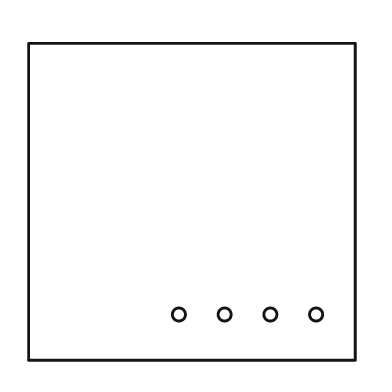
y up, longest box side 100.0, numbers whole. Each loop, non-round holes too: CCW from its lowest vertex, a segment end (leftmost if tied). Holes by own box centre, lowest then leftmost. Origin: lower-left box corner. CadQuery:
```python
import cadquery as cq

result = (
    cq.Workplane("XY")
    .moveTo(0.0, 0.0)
    .lineTo(100.0, 0.0)
    .lineTo(100.0, 97.0)
    .lineTo(0.0, 97.0)
    .close()
    .moveTo(46.0, 14.0)
    .circle(2.0)
    .moveTo(60.0, 14.0)
    .circle(2.0)
    .moveTo(74.0, 14.0)
    .circle(2.0)
    .moveTo(88.0, 14.0)
    .circle(2.0)
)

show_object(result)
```